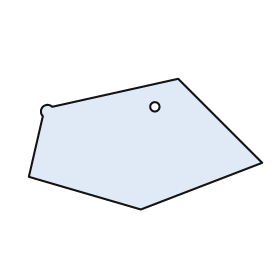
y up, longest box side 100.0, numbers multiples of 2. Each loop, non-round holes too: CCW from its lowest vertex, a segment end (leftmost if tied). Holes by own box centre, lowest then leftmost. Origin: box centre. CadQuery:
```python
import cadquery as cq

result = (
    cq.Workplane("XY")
    .moveTo(-2.0, -28.0)
    .lineTo(50.0, -8.0)
    .lineTo(14.0, 28.0)
    .lineTo(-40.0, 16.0)
    .threePointArc((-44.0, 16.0), (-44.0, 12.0))
    .lineTo(-50.0, -14.0)
    .close()
    .moveTo(4.0, 16.0)
    .circle(2.0)
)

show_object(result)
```